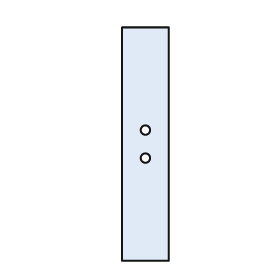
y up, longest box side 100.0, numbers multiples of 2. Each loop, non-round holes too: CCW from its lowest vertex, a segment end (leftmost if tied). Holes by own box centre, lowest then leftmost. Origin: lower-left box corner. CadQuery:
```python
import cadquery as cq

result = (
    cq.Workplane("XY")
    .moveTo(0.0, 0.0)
    .lineTo(20.0, 0.0)
    .lineTo(20.0, 100.0)
    .lineTo(0.0, 100.0)
    .close()
    .moveTo(10.0, 44.0)
    .circle(2.0)
    .moveTo(10.0, 56.0)
    .circle(2.0)
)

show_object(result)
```